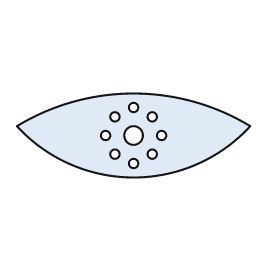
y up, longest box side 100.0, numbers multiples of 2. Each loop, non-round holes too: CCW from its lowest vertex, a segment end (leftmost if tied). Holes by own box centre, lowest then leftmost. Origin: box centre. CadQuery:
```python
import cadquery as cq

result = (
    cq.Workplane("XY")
    .moveTo(-50.0, 4.0)
    .threePointArc((0.0, -18.0), (50.0, 4.0))
    .threePointArc((0.0, 18.0), (-50.0, 4.0))
    .close()
    .moveTo(0.0, -12.0)
    .circle(2.0)
    .moveTo(-8.0, -8.0)
    .circle(2.0)
    .moveTo(8.0, -8.0)
    .circle(2.0)
    .moveTo(-12.0, 0.0)
    .circle(2.0)
    .moveTo(0.0, 0.0)
    .circle(4.0)
    .moveTo(12.0, 0.0)
    .circle(2.0)
    .moveTo(-8.0, 8.0)
    .circle(2.0)
    .moveTo(8.0, 8.0)
    .circle(2.0)
    .moveTo(0.0, 12.0)
    .circle(2.0)
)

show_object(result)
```